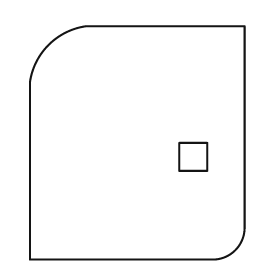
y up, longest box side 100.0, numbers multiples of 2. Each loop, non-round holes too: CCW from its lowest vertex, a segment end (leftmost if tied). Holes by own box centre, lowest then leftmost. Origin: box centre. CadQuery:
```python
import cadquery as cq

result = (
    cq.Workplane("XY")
    .moveTo(-46.0, -50.0)
    .lineTo(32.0, -50.0)
    .threePointArc((42.0, -46.0), (46.0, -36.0))
    .lineTo(46.0, 50.0)
    .lineTo(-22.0, 50.0)
    .threePointArc((-38.0, 42.0), (-46.0, 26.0))
    .close()
    .moveTo(18.0, -12.0)
    .lineTo(30.0, -12.0)
    .lineTo(30.0, 0.0)
    .lineTo(18.0, 0.0)
    .close()
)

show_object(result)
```